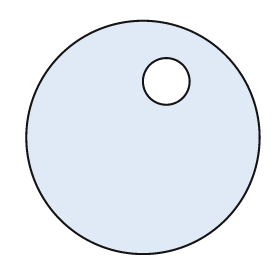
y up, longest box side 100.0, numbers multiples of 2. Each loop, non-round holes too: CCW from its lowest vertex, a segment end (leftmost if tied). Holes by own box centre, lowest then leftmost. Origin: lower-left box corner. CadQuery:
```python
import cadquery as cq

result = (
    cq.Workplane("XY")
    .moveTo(50.0, 50.0)
    .circle(50.0)
    .moveTo(60.0, 74.0)
    .circle(10.0)
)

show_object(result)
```